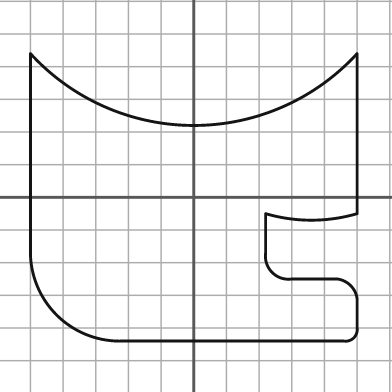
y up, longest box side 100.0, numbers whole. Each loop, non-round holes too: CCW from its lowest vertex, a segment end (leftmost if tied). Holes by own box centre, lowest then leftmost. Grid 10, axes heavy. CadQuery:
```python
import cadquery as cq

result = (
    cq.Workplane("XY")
    .moveTo(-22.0, -44.0)
    .lineTo(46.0, -44.0)
    .threePointArc((49.0, -43.0), (50.0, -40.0))
    .lineTo(50.0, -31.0)
    .threePointArc((48.0, -27.0), (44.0, -25.0))
    .lineTo(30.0, -25.0)
    .threePointArc((24.0, -23.0), (22.0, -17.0))
    .lineTo(22.0, -5.0)
    .threePointArc((36.0, -7.0), (50.0, -5.0))
    .lineTo(50.0, 44.0)
    .threePointArc((0.0, 22.0), (-50.0, 44.0))
    .lineTo(-50.0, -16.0)
    .threePointArc((-42.0, -36.0), (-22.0, -44.0))
    .close()
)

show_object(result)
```